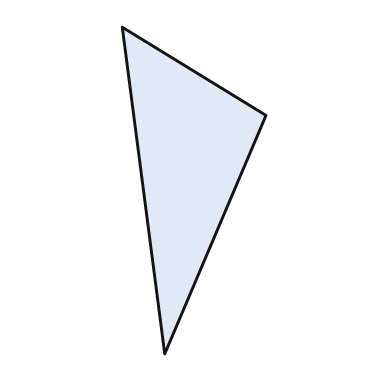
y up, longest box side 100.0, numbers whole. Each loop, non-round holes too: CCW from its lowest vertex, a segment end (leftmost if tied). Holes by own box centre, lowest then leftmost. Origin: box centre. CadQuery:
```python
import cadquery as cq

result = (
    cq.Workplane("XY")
    .moveTo(-9.0, -50.0)
    .lineTo(22.0, 23.0)
    .lineTo(-22.0, 50.0)
    .close()
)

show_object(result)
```